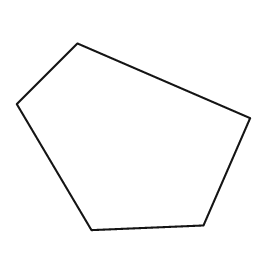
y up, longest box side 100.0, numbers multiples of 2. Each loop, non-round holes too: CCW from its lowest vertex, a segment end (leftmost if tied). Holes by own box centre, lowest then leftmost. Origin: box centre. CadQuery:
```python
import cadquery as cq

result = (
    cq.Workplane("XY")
    .moveTo(-18.0, -40.0)
    .lineTo(30.0, -38.0)
    .lineTo(50.0, 8.0)
    .lineTo(-24.0, 40.0)
    .lineTo(-50.0, 14.0)
    .close()
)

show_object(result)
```